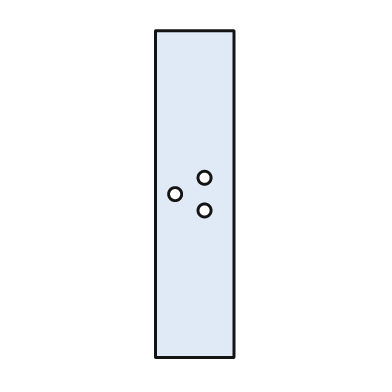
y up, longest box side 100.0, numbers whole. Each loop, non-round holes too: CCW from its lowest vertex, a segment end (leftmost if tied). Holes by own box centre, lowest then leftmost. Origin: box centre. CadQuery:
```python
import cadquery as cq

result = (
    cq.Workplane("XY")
    .moveTo(-12.0, -50.0)
    .lineTo(12.0, -50.0)
    .lineTo(12.0, 50.0)
    .lineTo(-12.0, 50.0)
    .close()
    .moveTo(3.0, -5.0)
    .circle(2.0)
    .moveTo(-6.0, 0.0)
    .circle(2.0)
    .moveTo(3.0, 5.0)
    .circle(2.0)
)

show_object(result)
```